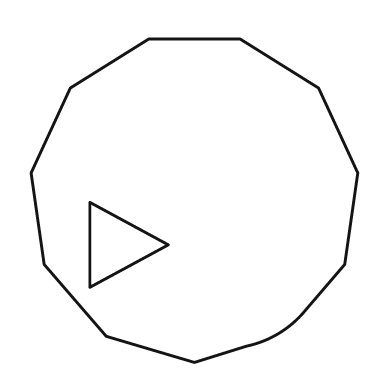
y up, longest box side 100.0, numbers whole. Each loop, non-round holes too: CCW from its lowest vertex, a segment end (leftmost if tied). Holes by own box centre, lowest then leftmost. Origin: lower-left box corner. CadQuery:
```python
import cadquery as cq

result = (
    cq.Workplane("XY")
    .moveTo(50.0, 0.0)
    .lineTo(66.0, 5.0)
    .threePointArc((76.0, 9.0), (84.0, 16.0))
    .lineTo(96.0, 30.0)
    .lineTo(100.0, 58.0)
    .lineTo(88.0, 84.0)
    .lineTo(64.0, 99.0)
    .lineTo(36.0, 99.0)
    .lineTo(12.0, 84.0)
    .lineTo(0.0, 58.0)
    .lineTo(4.0, 30.0)
    .lineTo(23.0, 8.0)
    .close()
    .moveTo(18.0, 23.0)
    .lineTo(42.0, 36.0)
    .lineTo(18.0, 49.0)
    .close()
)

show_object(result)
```